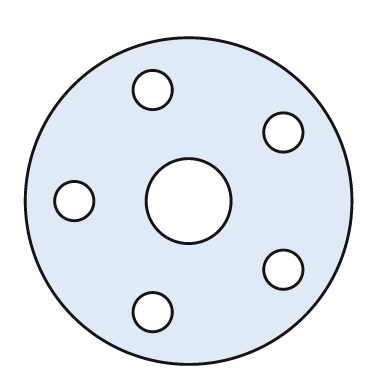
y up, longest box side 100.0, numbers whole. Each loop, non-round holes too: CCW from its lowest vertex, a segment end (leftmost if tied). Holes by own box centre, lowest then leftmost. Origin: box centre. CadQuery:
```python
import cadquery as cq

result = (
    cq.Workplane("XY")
    .moveTo(0.0, 0.0)
    .circle(50.0)
    .moveTo(-11.0, -34.0)
    .circle(6.0)
    .moveTo(29.0, -21.0)
    .circle(6.0)
    .moveTo(-35.0, 0.0)
    .circle(6.0)
    .moveTo(0.0, 0.0)
    .circle(13.0)
    .moveTo(29.0, 21.0)
    .circle(6.0)
    .moveTo(-11.0, 34.0)
    .circle(6.0)
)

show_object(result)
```